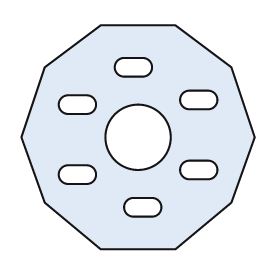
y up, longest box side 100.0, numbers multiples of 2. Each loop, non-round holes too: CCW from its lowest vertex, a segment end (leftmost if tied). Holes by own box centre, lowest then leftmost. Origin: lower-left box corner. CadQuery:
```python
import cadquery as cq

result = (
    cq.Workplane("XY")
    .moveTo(34.0, 0.0)
    .lineTo(66.0, 0.0)
    .lineTo(90.0, 20.0)
    .lineTo(100.0, 48.0)
    .lineTo(90.0, 78.0)
    .lineTo(66.0, 96.0)
    .lineTo(34.0, 96.0)
    .lineTo(10.0, 78.0)
    .lineTo(0.0, 48.0)
    .lineTo(10.0, 20.0)
    .close()
    .moveTo(48.0, 14.0)
    .lineTo(56.0, 14.0)
    .threePointArc((60.0, 18.0), (56.0, 22.0))
    .lineTo(48.0, 22.0)
    .threePointArc((44.0, 18.0), (48.0, 14.0))
    .close()
    .moveTo(20.0, 28.0)
    .lineTo(28.0, 28.0)
    .threePointArc((32.0, 32.0), (28.0, 36.0))
    .lineTo(20.0, 36.0)
    .threePointArc((16.0, 32.0), (20.0, 28.0))
    .close()
    .moveTo(72.0, 30.0)
    .lineTo(80.0, 30.0)
    .threePointArc((84.0, 34.0), (80.0, 38.0))
    .lineTo(72.0, 38.0)
    .threePointArc((68.0, 34.0), (72.0, 30.0))
    .close()
    .moveTo(50.0, 48.0)
    .circle(14.0)
    .moveTo(20.0, 58.0)
    .lineTo(28.0, 58.0)
    .threePointArc((32.0, 62.0), (28.0, 66.0))
    .lineTo(20.0, 66.0)
    .threePointArc((16.0, 62.0), (20.0, 58.0))
    .close()
    .moveTo(72.0, 60.0)
    .lineTo(80.0, 60.0)
    .threePointArc((84.0, 64.0), (80.0, 68.0))
    .lineTo(72.0, 68.0)
    .threePointArc((68.0, 64.0), (72.0, 60.0))
    .close()
    .moveTo(44.0, 74.0)
    .lineTo(52.0, 74.0)
    .threePointArc((56.0, 78.0), (52.0, 82.0))
    .lineTo(44.0, 82.0)
    .threePointArc((40.0, 78.0), (44.0, 74.0))
    .close()
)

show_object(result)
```